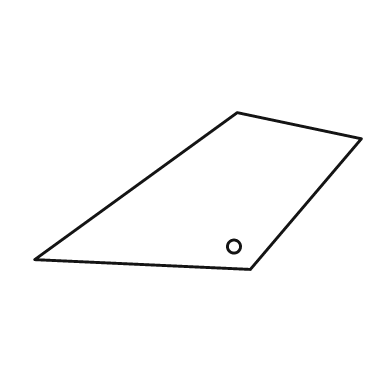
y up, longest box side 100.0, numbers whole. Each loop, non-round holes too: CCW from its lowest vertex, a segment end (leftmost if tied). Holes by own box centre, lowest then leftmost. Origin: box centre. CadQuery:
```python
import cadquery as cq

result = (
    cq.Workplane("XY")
    .moveTo(16.0, -24.0)
    .lineTo(50.0, 16.0)
    .lineTo(12.0, 24.0)
    .lineTo(-50.0, -21.0)
    .close()
    .moveTo(11.0, -17.0)
    .circle(2.0)
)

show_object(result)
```